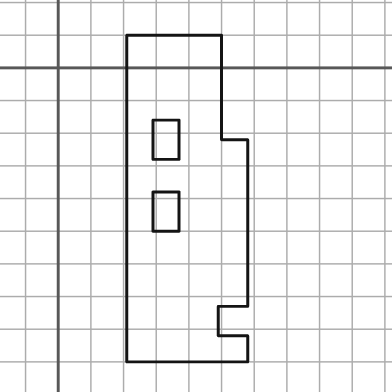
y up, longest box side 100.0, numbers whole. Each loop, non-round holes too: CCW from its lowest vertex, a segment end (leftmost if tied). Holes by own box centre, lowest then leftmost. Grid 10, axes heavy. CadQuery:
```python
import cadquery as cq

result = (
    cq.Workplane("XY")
    .moveTo(21.0, -90.0)
    .lineTo(58.0, -90.0)
    .lineTo(58.0, -82.0)
    .lineTo(49.0, -82.0)
    .lineTo(49.0, -73.0)
    .lineTo(58.0, -73.0)
    .lineTo(58.0, -22.0)
    .lineTo(50.0, -22.0)
    .lineTo(50.0, 10.0)
    .lineTo(21.0, 10.0)
    .close()
    .moveTo(29.0, -50.0)
    .lineTo(37.0, -50.0)
    .lineTo(37.0, -38.0)
    .lineTo(29.0, -38.0)
    .close()
    .moveTo(29.0, -28.0)
    .lineTo(37.0, -28.0)
    .lineTo(37.0, -16.0)
    .lineTo(29.0, -16.0)
    .close()
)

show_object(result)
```